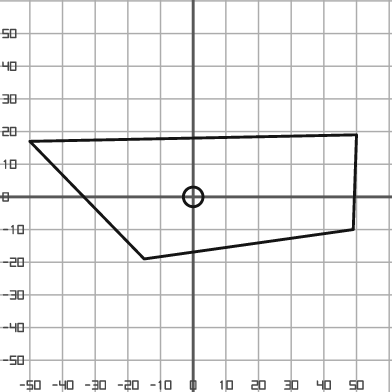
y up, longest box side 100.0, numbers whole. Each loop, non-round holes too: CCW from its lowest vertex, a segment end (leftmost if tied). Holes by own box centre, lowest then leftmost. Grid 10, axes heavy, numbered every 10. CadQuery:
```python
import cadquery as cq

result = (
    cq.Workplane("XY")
    .moveTo(-15.0, -19.0)
    .lineTo(49.0, -10.0)
    .lineTo(50.0, 19.0)
    .lineTo(-50.0, 17.0)
    .close()
    .moveTo(0.0, 0.0)
    .circle(3.0)
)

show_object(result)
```